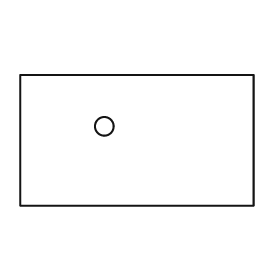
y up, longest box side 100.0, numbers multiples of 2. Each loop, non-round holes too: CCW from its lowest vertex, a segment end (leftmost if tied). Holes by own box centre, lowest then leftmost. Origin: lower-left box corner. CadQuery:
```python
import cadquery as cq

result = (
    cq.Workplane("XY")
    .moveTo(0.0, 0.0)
    .lineTo(100.0, 0.0)
    .lineTo(100.0, 56.0)
    .lineTo(0.0, 56.0)
    .close()
    .moveTo(36.0, 34.0)
    .circle(4.0)
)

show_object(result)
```